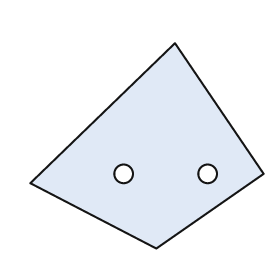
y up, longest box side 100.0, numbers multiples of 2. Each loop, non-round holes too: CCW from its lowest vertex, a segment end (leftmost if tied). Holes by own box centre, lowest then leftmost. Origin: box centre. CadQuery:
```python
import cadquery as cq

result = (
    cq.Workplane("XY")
    .moveTo(4.0, -44.0)
    .lineTo(50.0, -12.0)
    .lineTo(12.0, 44.0)
    .lineTo(-50.0, -16.0)
    .close()
    .moveTo(-10.0, -12.0)
    .circle(4.0)
    .moveTo(26.0, -12.0)
    .circle(4.0)
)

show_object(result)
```